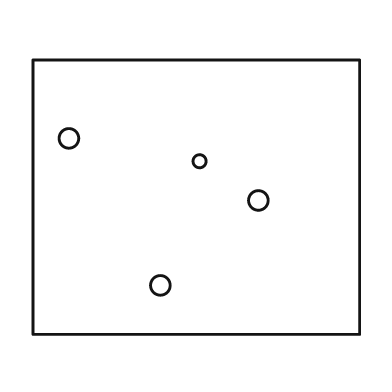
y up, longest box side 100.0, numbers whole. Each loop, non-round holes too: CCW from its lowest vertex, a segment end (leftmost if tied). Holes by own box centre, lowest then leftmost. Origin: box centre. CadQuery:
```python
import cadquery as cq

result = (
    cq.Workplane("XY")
    .moveTo(-50.0, -42.0)
    .lineTo(50.0, -42.0)
    .lineTo(50.0, 42.0)
    .lineTo(-50.0, 42.0)
    .close()
    .moveTo(-11.0, -27.0)
    .circle(3.0)
    .moveTo(19.0, -1.0)
    .circle(3.0)
    .moveTo(1.0, 11.0)
    .circle(2.0)
    .moveTo(-39.0, 18.0)
    .circle(3.0)
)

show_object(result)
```